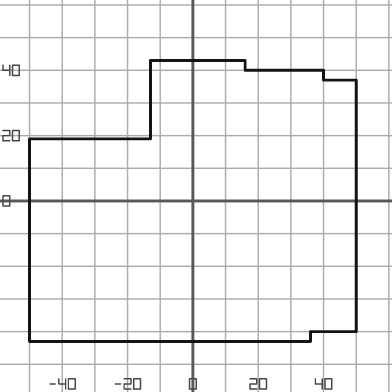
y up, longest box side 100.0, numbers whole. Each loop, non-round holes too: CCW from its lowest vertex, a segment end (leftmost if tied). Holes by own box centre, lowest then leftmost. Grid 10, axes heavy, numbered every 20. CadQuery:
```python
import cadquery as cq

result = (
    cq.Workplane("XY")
    .moveTo(-50.0, -43.0)
    .lineTo(36.0, -43.0)
    .lineTo(36.0, -40.0)
    .lineTo(50.0, -40.0)
    .lineTo(50.0, 37.0)
    .lineTo(40.0, 37.0)
    .lineTo(40.0, 40.0)
    .lineTo(16.0, 40.0)
    .lineTo(16.0, 43.0)
    .lineTo(-13.0, 43.0)
    .lineTo(-13.0, 19.0)
    .lineTo(-50.0, 19.0)
    .close()
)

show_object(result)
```